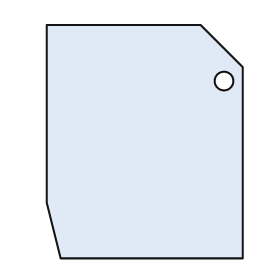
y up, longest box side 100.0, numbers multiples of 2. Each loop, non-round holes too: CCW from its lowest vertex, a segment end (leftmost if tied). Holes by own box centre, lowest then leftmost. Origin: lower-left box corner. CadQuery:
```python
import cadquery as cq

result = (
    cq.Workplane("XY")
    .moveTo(6.0, 0.0)
    .lineTo(84.0, 0.0)
    .lineTo(84.0, 82.0)
    .lineTo(66.0, 100.0)
    .lineTo(0.0, 100.0)
    .lineTo(0.0, 24.0)
    .close()
    .moveTo(76.0, 76.0)
    .circle(4.0)
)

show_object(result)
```